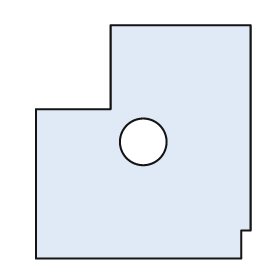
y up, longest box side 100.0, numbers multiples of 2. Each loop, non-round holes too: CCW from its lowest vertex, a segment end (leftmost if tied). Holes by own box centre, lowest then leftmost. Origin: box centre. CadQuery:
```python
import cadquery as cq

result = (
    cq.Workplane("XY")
    .moveTo(-46.0, -50.0)
    .lineTo(42.0, -50.0)
    .lineTo(42.0, -38.0)
    .lineTo(46.0, -38.0)
    .lineTo(46.0, 50.0)
    .lineTo(-14.0, 50.0)
    .lineTo(-14.0, 14.0)
    .lineTo(-46.0, 14.0)
    .close()
    .moveTo(0.0, 0.0)
    .circle(10.0)
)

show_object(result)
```